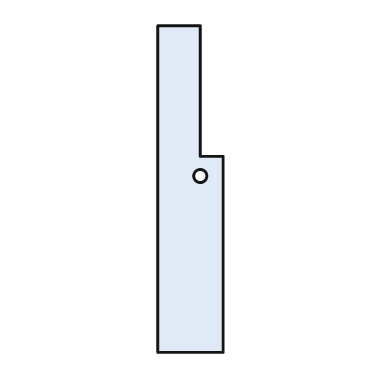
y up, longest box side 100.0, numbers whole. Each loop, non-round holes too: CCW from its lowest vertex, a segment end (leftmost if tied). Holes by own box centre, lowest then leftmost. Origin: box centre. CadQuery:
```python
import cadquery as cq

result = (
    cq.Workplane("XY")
    .moveTo(-10.0, -50.0)
    .lineTo(10.0, -50.0)
    .lineTo(10.0, 10.0)
    .lineTo(3.0, 10.0)
    .lineTo(3.0, 50.0)
    .lineTo(-10.0, 50.0)
    .close()
    .moveTo(3.0, 4.0)
    .circle(2.0)
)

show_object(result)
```